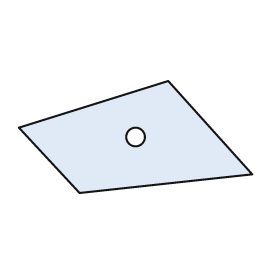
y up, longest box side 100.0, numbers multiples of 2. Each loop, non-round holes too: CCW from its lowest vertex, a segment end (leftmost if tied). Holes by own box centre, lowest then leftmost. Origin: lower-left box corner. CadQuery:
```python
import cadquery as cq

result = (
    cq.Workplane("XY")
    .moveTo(26.0, 0.0)
    .lineTo(100.0, 8.0)
    .lineTo(64.0, 48.0)
    .lineTo(0.0, 28.0)
    .close()
    .moveTo(50.0, 24.0)
    .circle(4.0)
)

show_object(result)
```